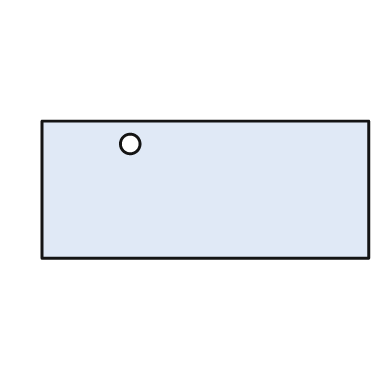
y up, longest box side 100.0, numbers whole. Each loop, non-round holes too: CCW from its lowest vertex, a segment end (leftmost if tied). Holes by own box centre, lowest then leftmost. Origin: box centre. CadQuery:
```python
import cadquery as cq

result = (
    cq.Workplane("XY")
    .moveTo(-50.0, -21.0)
    .lineTo(50.0, -21.0)
    .lineTo(50.0, 21.0)
    .lineTo(-50.0, 21.0)
    .close()
    .moveTo(-23.0, 14.0)
    .circle(3.0)
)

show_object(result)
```